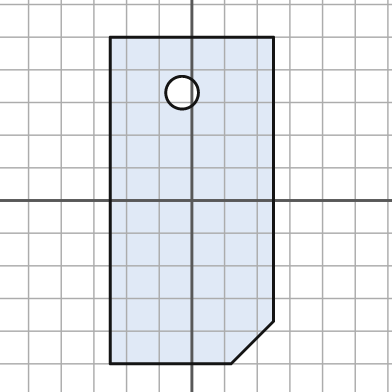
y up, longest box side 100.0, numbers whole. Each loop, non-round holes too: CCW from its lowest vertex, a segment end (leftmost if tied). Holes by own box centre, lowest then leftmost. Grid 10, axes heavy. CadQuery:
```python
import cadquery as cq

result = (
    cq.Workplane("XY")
    .moveTo(-25.0, -50.0)
    .lineTo(12.0, -50.0)
    .lineTo(25.0, -37.0)
    .lineTo(25.0, 50.0)
    .lineTo(-25.0, 50.0)
    .close()
    .moveTo(-3.0, 33.0)
    .circle(5.0)
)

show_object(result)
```